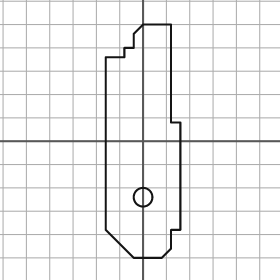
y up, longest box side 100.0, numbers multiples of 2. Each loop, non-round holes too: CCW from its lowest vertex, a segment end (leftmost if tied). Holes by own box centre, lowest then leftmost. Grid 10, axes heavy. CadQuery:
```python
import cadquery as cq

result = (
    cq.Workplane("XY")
    .moveTo(-4.0, -50.0)
    .lineTo(8.0, -50.0)
    .lineTo(12.0, -46.0)
    .lineTo(12.0, -38.0)
    .lineTo(16.0, -38.0)
    .lineTo(16.0, 8.0)
    .lineTo(12.0, 8.0)
    .lineTo(12.0, 50.0)
    .lineTo(0.0, 50.0)
    .lineTo(-4.0, 46.0)
    .lineTo(-4.0, 40.0)
    .lineTo(-8.0, 40.0)
    .lineTo(-8.0, 36.0)
    .lineTo(-16.0, 36.0)
    .lineTo(-16.0, -38.0)
    .close()
    .moveTo(0.0, -24.0)
    .circle(4.0)
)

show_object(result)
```